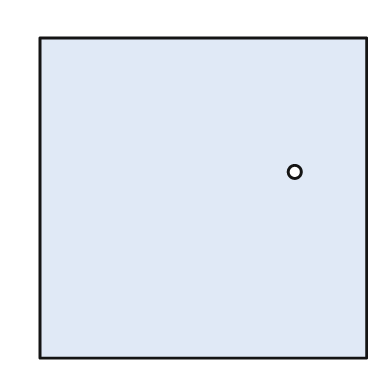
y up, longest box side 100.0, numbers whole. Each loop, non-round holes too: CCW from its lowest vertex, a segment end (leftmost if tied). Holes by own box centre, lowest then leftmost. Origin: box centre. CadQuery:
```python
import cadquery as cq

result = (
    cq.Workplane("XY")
    .moveTo(-50.0, -49.0)
    .lineTo(50.0, -49.0)
    .lineTo(50.0, 49.0)
    .lineTo(-50.0, 49.0)
    .close()
    .moveTo(28.0, 8.0)
    .circle(2.0)
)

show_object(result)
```